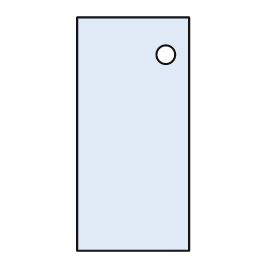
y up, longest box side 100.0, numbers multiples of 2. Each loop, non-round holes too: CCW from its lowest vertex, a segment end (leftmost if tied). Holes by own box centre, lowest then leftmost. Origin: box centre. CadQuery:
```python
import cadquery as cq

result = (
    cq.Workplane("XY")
    .moveTo(-24.0, -50.0)
    .lineTo(24.0, -50.0)
    .lineTo(24.0, 50.0)
    .lineTo(-24.0, 50.0)
    .close()
    .moveTo(14.0, 34.0)
    .circle(4.0)
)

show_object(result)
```